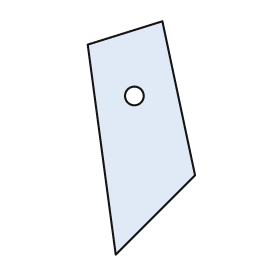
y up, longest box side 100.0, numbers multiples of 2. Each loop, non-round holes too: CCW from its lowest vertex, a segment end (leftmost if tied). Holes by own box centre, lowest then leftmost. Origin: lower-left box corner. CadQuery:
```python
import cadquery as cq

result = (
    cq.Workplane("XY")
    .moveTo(12.0, 0.0)
    .lineTo(46.0, 34.0)
    .lineTo(32.0, 100.0)
    .lineTo(0.0, 90.0)
    .close()
    .moveTo(20.0, 68.0)
    .circle(4.0)
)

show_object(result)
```